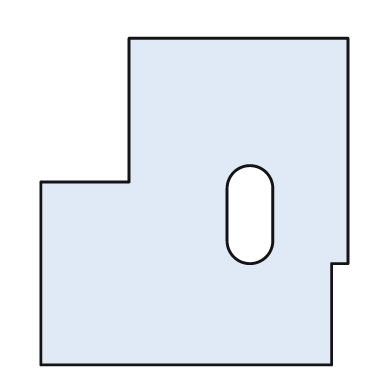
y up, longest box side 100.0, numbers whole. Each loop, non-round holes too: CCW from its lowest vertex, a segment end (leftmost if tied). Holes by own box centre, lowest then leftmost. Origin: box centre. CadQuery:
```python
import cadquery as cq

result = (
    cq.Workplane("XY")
    .moveTo(-47.0, -50.0)
    .lineTo(42.0, -50.0)
    .lineTo(42.0, -19.0)
    .lineTo(47.0, -19.0)
    .lineTo(47.0, 50.0)
    .lineTo(-20.0, 50.0)
    .lineTo(-20.0, 6.0)
    .lineTo(-47.0, 6.0)
    .close()
    .moveTo(10.0, -12.0)
    .threePointArc((17.0, -19.0), (24.0, -12.0))
    .lineTo(24.0, 4.0)
    .threePointArc((17.0, 11.0), (10.0, 4.0))
    .close()
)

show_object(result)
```